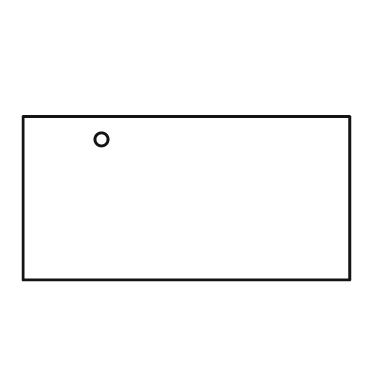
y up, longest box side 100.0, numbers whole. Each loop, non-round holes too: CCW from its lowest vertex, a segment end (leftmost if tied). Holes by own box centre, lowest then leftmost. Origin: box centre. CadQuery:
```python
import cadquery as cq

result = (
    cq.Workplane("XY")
    .moveTo(-50.0, -25.0)
    .lineTo(50.0, -25.0)
    .lineTo(50.0, 25.0)
    .lineTo(-50.0, 25.0)
    .close()
    .moveTo(-26.0, 18.0)
    .circle(2.0)
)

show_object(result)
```